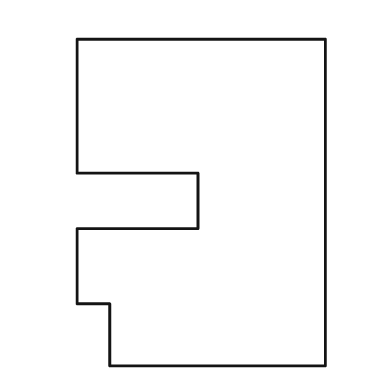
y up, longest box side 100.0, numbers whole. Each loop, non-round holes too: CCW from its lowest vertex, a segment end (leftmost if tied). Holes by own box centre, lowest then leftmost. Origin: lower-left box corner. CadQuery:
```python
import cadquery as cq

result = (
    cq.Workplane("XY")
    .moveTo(10.0, 0.0)
    .lineTo(76.0, 0.0)
    .lineTo(76.0, 100.0)
    .lineTo(0.0, 100.0)
    .lineTo(0.0, 59.0)
    .lineTo(37.0, 59.0)
    .lineTo(37.0, 42.0)
    .lineTo(0.0, 42.0)
    .lineTo(0.0, 19.0)
    .lineTo(10.0, 19.0)
    .close()
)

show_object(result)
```